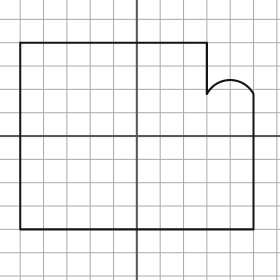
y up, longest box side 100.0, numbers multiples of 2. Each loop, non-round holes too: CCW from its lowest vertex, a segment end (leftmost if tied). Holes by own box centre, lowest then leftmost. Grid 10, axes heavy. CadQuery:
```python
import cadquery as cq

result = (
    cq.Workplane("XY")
    .moveTo(-50.0, -40.0)
    .lineTo(50.0, -40.0)
    .lineTo(50.0, 18.0)
    .threePointArc((40.0, 24.0), (30.0, 18.0))
    .lineTo(30.0, 40.0)
    .lineTo(-50.0, 40.0)
    .close()
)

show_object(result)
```